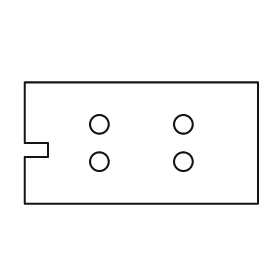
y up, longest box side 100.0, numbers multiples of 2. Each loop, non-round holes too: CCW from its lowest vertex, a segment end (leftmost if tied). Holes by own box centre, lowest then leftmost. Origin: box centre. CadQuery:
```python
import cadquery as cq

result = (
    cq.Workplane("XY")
    .moveTo(-50.0, -26.0)
    .lineTo(50.0, -26.0)
    .lineTo(50.0, 26.0)
    .lineTo(-50.0, 26.0)
    .lineTo(-50.0, 0.0)
    .lineTo(-40.0, 0.0)
    .lineTo(-40.0, -6.0)
    .lineTo(-50.0, -6.0)
    .close()
    .moveTo(-18.0, -8.0)
    .circle(4.0)
    .moveTo(18.0, -8.0)
    .circle(4.0)
    .moveTo(-18.0, 8.0)
    .circle(4.0)
    .moveTo(18.0, 8.0)
    .circle(4.0)
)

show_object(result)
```